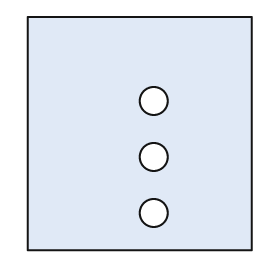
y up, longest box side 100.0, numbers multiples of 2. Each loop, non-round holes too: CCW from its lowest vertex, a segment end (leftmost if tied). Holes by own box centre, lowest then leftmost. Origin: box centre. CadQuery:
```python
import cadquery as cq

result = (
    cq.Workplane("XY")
    .moveTo(-48.0, -50.0)
    .lineTo(48.0, -50.0)
    .lineTo(48.0, 50.0)
    .lineTo(-48.0, 50.0)
    .close()
    .moveTo(6.0, -34.0)
    .circle(6.0)
    .moveTo(6.0, -10.0)
    .circle(6.0)
    .moveTo(6.0, 14.0)
    .circle(6.0)
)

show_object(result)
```